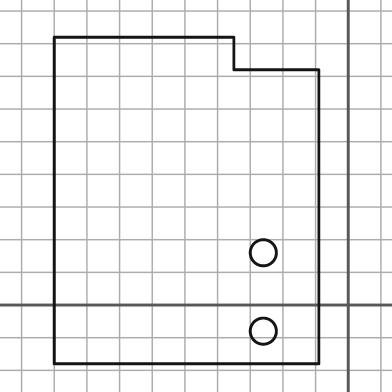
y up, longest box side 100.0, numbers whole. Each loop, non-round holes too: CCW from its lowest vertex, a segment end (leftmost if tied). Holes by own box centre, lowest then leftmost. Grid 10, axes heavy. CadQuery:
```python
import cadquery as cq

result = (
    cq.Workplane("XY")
    .moveTo(-90.0, -18.0)
    .lineTo(-9.0, -18.0)
    .lineTo(-9.0, 72.0)
    .lineTo(-35.0, 72.0)
    .lineTo(-35.0, 82.0)
    .lineTo(-90.0, 82.0)
    .close()
    .moveTo(-26.0, -8.0)
    .circle(4.0)
    .moveTo(-26.0, 16.0)
    .circle(4.0)
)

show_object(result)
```